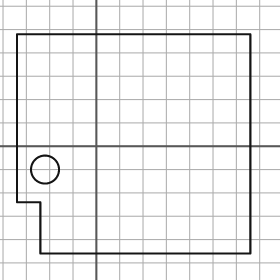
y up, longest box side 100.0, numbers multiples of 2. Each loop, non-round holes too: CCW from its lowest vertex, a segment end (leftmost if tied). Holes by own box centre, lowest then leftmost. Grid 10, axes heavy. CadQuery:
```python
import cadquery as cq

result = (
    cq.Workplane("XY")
    .moveTo(-24.0, -46.0)
    .lineTo(66.0, -46.0)
    .lineTo(66.0, 48.0)
    .lineTo(-34.0, 48.0)
    .lineTo(-34.0, -24.0)
    .lineTo(-24.0, -24.0)
    .close()
    .moveTo(-22.0, -10.0)
    .circle(6.0)
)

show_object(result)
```